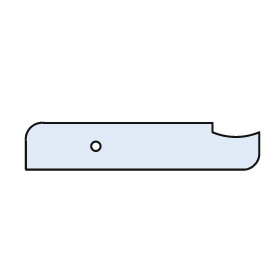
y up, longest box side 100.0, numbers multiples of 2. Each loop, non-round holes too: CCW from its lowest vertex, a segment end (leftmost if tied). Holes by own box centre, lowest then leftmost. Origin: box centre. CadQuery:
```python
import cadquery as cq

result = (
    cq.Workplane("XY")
    .moveTo(-50.0, -10.0)
    .lineTo(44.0, -10.0)
    .threePointArc((48.0, -8.0), (50.0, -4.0))
    .lineTo(50.0, 6.0)
    .threePointArc((40.0, 4.0), (30.0, 6.0))
    .lineTo(30.0, 10.0)
    .lineTo(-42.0, 10.0)
    .threePointArc((-48.0, 8.0), (-50.0, 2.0))
    .close()
    .moveTo(-20.0, 0.0)
    .circle(2.0)
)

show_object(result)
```